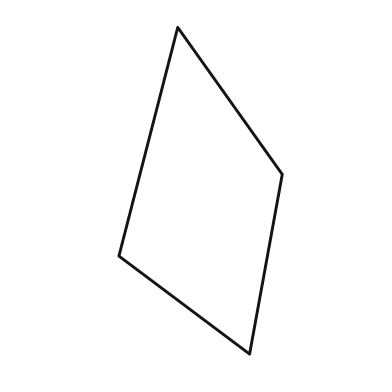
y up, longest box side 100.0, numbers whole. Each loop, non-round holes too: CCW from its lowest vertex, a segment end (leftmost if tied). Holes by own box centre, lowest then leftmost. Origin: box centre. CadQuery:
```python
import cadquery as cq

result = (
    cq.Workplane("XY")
    .moveTo(15.0, -50.0)
    .lineTo(25.0, 5.0)
    .lineTo(-7.0, 50.0)
    .lineTo(-25.0, -20.0)
    .close()
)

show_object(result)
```